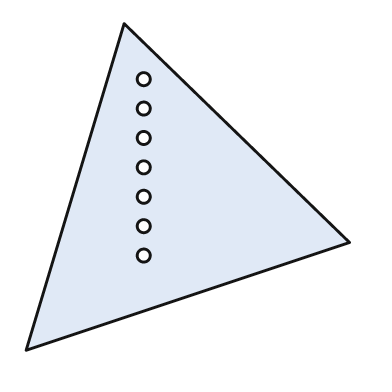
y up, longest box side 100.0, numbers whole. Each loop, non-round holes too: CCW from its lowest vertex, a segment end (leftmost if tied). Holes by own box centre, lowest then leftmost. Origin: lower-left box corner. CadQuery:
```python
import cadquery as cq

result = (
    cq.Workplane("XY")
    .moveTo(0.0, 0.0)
    .lineTo(99.0, 33.0)
    .lineTo(30.0, 100.0)
    .close()
    .moveTo(36.0, 29.0)
    .circle(2.0)
    .moveTo(36.0, 38.0)
    .circle(2.0)
    .moveTo(36.0, 47.0)
    .circle(2.0)
    .moveTo(36.0, 56.0)
    .circle(2.0)
    .moveTo(36.0, 65.0)
    .circle(2.0)
    .moveTo(36.0, 74.0)
    .circle(2.0)
    .moveTo(36.0, 83.0)
    .circle(2.0)
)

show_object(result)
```